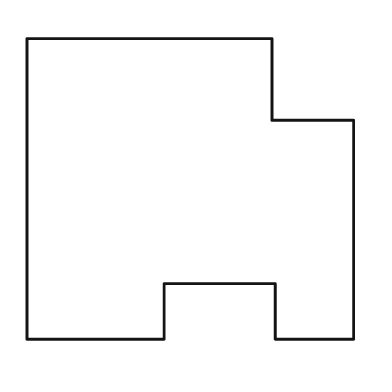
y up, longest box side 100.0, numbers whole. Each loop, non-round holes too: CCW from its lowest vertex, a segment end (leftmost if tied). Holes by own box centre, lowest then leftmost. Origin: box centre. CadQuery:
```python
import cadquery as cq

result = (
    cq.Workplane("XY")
    .moveTo(-50.0, -46.0)
    .lineTo(-8.0, -46.0)
    .lineTo(-8.0, -29.0)
    .lineTo(26.0, -29.0)
    .lineTo(26.0, -46.0)
    .lineTo(50.0, -46.0)
    .lineTo(50.0, 21.0)
    .lineTo(25.0, 21.0)
    .lineTo(25.0, 46.0)
    .lineTo(-50.0, 46.0)
    .close()
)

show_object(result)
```